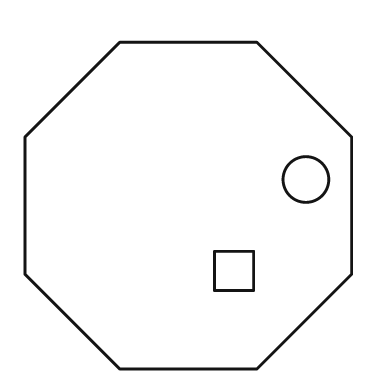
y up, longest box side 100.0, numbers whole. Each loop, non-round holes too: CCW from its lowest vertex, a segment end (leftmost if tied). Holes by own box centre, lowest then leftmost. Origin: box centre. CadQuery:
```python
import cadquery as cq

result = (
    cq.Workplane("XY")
    .moveTo(-21.0, -50.0)
    .lineTo(21.0, -50.0)
    .lineTo(50.0, -21.0)
    .lineTo(50.0, 21.0)
    .lineTo(21.0, 50.0)
    .lineTo(-21.0, 50.0)
    .lineTo(-50.0, 21.0)
    .lineTo(-50.0, -21.0)
    .close()
    .moveTo(8.0, -26.0)
    .lineTo(20.0, -26.0)
    .lineTo(20.0, -14.0)
    .lineTo(8.0, -14.0)
    .close()
    .moveTo(36.0, 8.0)
    .circle(7.0)
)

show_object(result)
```